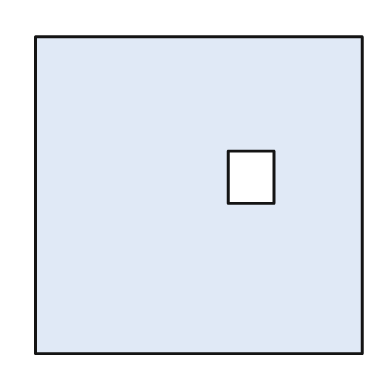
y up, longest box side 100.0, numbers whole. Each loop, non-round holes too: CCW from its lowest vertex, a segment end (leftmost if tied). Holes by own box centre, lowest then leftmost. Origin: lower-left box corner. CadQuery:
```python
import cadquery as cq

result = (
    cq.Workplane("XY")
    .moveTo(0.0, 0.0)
    .lineTo(100.0, 0.0)
    .lineTo(100.0, 97.0)
    .lineTo(0.0, 97.0)
    .close()
    .moveTo(59.0, 46.0)
    .lineTo(73.0, 46.0)
    .lineTo(73.0, 62.0)
    .lineTo(59.0, 62.0)
    .close()
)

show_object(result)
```